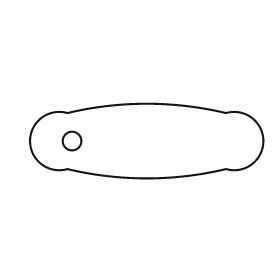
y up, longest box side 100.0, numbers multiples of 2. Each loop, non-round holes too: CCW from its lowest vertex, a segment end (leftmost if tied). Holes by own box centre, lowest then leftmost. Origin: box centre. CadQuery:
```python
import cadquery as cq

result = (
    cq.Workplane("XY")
    .moveTo(-34.0, -12.0)
    .threePointArc((0.0, -16.0), (34.0, -12.0))
    .threePointArc((50.0, 0.0), (34.0, 12.0))
    .threePointArc((0.0, 16.0), (-34.0, 12.0))
    .threePointArc((-50.0, 0.0), (-34.0, -12.0))
    .close()
    .moveTo(-32.0, 0.0)
    .circle(4.0)
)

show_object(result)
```